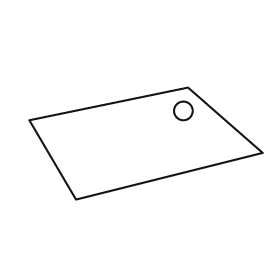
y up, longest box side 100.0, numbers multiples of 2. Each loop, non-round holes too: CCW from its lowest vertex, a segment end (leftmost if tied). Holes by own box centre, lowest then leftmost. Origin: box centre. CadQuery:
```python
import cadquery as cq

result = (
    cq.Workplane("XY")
    .moveTo(-30.0, -24.0)
    .lineTo(50.0, -4.0)
    .lineTo(18.0, 24.0)
    .lineTo(-50.0, 10.0)
    .close()
    .moveTo(16.0, 14.0)
    .circle(4.0)
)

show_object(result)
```